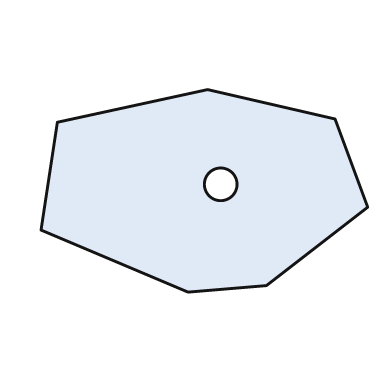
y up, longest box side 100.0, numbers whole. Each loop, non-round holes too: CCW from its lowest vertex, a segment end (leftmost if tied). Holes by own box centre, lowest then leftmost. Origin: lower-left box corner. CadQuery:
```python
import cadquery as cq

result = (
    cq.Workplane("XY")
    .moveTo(45.0, 0.0)
    .lineTo(69.0, 2.0)
    .lineTo(100.0, 26.0)
    .lineTo(90.0, 53.0)
    .lineTo(51.0, 62.0)
    .lineTo(5.0, 52.0)
    .lineTo(0.0, 19.0)
    .close()
    .moveTo(55.0, 33.0)
    .circle(5.0)
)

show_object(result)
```